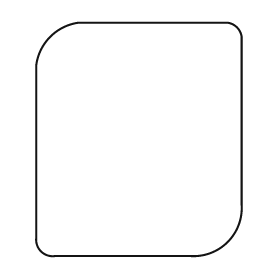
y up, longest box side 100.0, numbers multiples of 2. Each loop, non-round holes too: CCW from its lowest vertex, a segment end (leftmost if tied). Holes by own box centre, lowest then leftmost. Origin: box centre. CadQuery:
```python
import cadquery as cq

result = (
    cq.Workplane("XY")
    .moveTo(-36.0, -50.0)
    .lineTo(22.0, -50.0)
    .threePointArc((38.0, -44.0), (44.0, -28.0))
    .lineTo(44.0, 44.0)
    .threePointArc((42.0, 48.0), (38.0, 50.0))
    .lineTo(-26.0, 50.0)
    .threePointArc((-38.0, 44.0), (-44.0, 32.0))
    .lineTo(-44.0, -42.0)
    .threePointArc((-42.0, -48.0), (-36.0, -50.0))
    .close()
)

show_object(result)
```